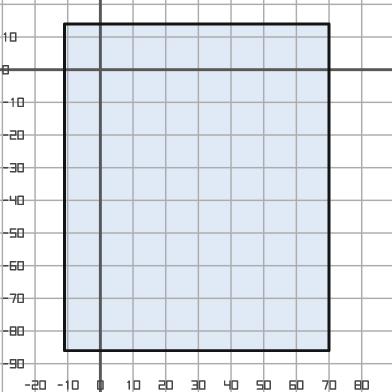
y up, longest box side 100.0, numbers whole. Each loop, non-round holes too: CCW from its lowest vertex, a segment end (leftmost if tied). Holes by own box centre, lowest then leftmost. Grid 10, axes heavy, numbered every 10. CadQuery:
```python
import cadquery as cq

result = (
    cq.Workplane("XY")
    .moveTo(-11.0, -86.0)
    .lineTo(70.0, -86.0)
    .lineTo(70.0, 14.0)
    .lineTo(-11.0, 14.0)
    .close()
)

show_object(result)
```